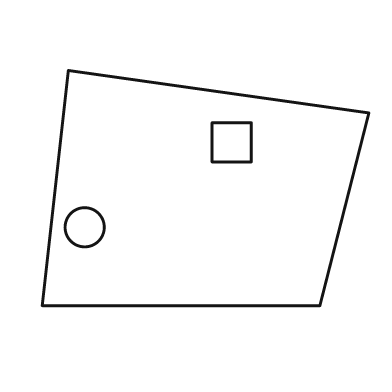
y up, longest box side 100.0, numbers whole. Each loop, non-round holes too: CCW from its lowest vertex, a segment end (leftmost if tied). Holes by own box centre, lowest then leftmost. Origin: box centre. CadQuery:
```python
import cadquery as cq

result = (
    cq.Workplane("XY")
    .moveTo(-50.0, -36.0)
    .lineTo(35.0, -36.0)
    .lineTo(50.0, 23.0)
    .lineTo(-42.0, 36.0)
    .close()
    .moveTo(-37.0, -12.0)
    .circle(6.0)
    .moveTo(2.0, 8.0)
    .lineTo(14.0, 8.0)
    .lineTo(14.0, 20.0)
    .lineTo(2.0, 20.0)
    .close()
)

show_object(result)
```